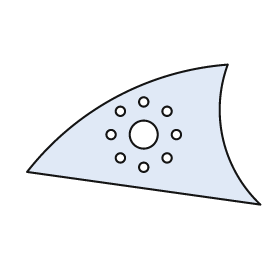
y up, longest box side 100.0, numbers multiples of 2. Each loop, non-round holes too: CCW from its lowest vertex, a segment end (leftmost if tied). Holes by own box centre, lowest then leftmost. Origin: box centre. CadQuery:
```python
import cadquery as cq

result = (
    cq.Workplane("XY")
    .moveTo(50.0, -30.0)
    .threePointArc((34.0, -2.0), (36.0, 30.0))
    .threePointArc((-12.0, 16.0), (-50.0, -16.0))
    .close()
    .moveTo(0.0, -14.0)
    .circle(2.0)
    .moveTo(-10.0, -10.0)
    .circle(2.0)
    .moveTo(10.0, -10.0)
    .circle(2.0)
    .moveTo(-14.0, 0.0)
    .circle(2.0)
    .moveTo(0.0, 0.0)
    .circle(6.0)
    .moveTo(14.0, 0.0)
    .circle(2.0)
    .moveTo(-10.0, 10.0)
    .circle(2.0)
    .moveTo(10.0, 10.0)
    .circle(2.0)
    .moveTo(0.0, 14.0)
    .circle(2.0)
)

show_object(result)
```